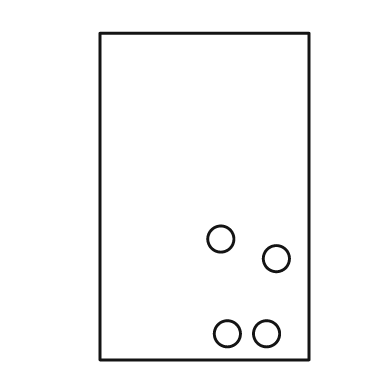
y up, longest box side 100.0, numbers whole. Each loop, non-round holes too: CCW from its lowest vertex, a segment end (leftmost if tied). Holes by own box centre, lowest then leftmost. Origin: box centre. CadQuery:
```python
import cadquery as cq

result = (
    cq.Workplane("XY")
    .moveTo(-32.0, -50.0)
    .lineTo(32.0, -50.0)
    .lineTo(32.0, 50.0)
    .lineTo(-32.0, 50.0)
    .close()
    .moveTo(7.0, -42.0)
    .circle(4.0)
    .moveTo(19.0, -42.0)
    .circle(4.0)
    .moveTo(22.0, -19.0)
    .circle(4.0)
    .moveTo(5.0, -13.0)
    .circle(4.0)
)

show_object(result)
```